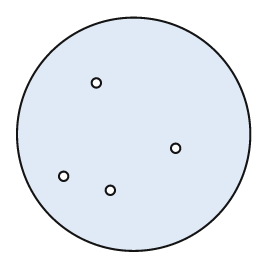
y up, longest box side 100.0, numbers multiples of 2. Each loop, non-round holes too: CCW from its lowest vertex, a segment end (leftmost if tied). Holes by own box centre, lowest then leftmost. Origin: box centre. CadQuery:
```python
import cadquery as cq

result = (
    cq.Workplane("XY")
    .moveTo(0.0, 0.0)
    .circle(50.0)
    .moveTo(-10.0, -24.0)
    .circle(2.0)
    .moveTo(-30.0, -18.0)
    .circle(2.0)
    .moveTo(18.0, -6.0)
    .circle(2.0)
    .moveTo(-16.0, 22.0)
    .circle(2.0)
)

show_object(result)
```